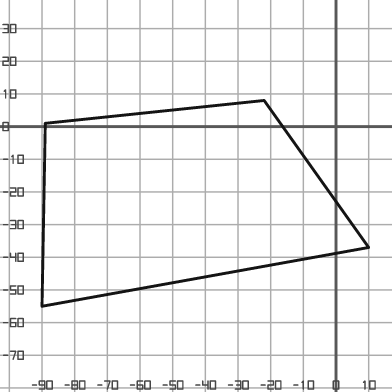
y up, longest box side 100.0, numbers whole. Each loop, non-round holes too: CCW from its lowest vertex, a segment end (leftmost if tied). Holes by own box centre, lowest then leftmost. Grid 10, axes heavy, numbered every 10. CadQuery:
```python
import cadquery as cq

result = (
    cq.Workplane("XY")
    .moveTo(-90.0, -55.0)
    .lineTo(10.0, -37.0)
    .lineTo(-22.0, 8.0)
    .lineTo(-89.0, 1.0)
    .close()
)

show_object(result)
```